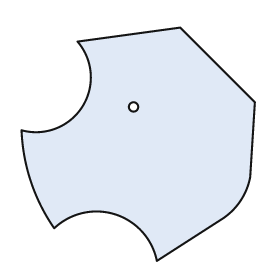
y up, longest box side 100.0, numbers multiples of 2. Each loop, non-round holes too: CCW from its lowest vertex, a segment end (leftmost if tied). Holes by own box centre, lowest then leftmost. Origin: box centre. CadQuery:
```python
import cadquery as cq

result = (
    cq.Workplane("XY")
    .moveTo(8.0, -50.0)
    .lineTo(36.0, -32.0)
    .threePointArc((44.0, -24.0), (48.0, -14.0))
    .lineTo(50.0, 18.0)
    .lineTo(18.0, 50.0)
    .lineTo(-26.0, 44.0)
    .threePointArc((-24.0, 16.0), (-50.0, 6.0))
    .threePointArc((-46.0, -16.0), (-36.0, -36.0))
    .threePointArc((-10.0, -30.0), (8.0, -50.0))
    .close()
    .moveTo(-2.0, 16.0)
    .circle(2.0)
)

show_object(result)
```